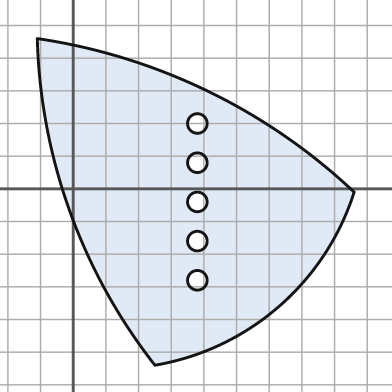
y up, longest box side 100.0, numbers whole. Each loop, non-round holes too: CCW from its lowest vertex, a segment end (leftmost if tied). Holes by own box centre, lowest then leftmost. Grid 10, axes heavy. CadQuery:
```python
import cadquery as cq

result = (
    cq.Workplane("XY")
    .moveTo(25.0, -54.0)
    .threePointArc((63.0, -36.0), (86.0, -1.0))
    .threePointArc((41.0, 30.0), (-11.0, 46.0))
    .threePointArc((-1.0, -7.0), (25.0, -54.0))
    .close()
    .moveTo(38.0, -28.0)
    .circle(3.0)
    .moveTo(38.0, -16.0)
    .circle(3.0)
    .moveTo(38.0, -4.0)
    .circle(3.0)
    .moveTo(38.0, 8.0)
    .circle(3.0)
    .moveTo(38.0, 20.0)
    .circle(3.0)
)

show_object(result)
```